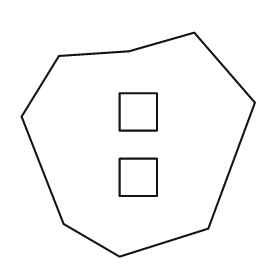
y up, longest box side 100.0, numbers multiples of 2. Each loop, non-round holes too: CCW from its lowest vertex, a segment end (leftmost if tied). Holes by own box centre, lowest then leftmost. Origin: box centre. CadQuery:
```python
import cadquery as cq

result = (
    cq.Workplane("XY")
    .moveTo(-8.0, -48.0)
    .lineTo(30.0, -36.0)
    .lineTo(50.0, 18.0)
    .lineTo(24.0, 48.0)
    .lineTo(-4.0, 40.0)
    .lineTo(-34.0, 38.0)
    .lineTo(-50.0, 12.0)
    .lineTo(-32.0, -34.0)
    .close()
    .moveTo(-8.0, -22.0)
    .lineTo(8.0, -22.0)
    .lineTo(8.0, -6.0)
    .lineTo(-8.0, -6.0)
    .close()
    .moveTo(-8.0, 6.0)
    .lineTo(8.0, 6.0)
    .lineTo(8.0, 22.0)
    .lineTo(-8.0, 22.0)
    .close()
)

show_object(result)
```